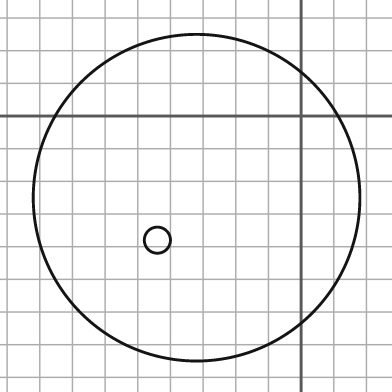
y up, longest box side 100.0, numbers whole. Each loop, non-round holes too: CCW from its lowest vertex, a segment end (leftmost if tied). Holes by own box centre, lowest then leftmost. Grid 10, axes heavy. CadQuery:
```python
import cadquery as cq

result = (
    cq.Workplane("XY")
    .moveTo(-32.0, -25.0)
    .circle(50.0)
    .moveTo(-44.0, -38.0)
    .circle(4.0)
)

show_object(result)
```